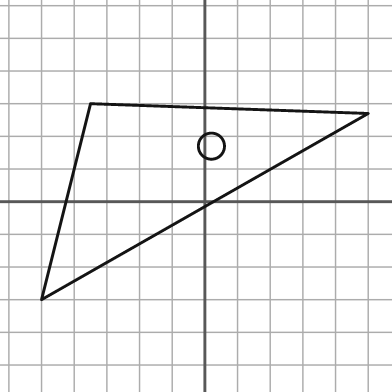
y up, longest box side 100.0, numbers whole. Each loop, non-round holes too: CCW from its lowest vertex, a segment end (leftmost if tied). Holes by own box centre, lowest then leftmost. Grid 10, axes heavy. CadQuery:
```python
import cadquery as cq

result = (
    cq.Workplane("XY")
    .moveTo(-50.0, -30.0)
    .lineTo(50.0, 27.0)
    .lineTo(-35.0, 30.0)
    .close()
    .moveTo(2.0, 17.0)
    .circle(4.0)
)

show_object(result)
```